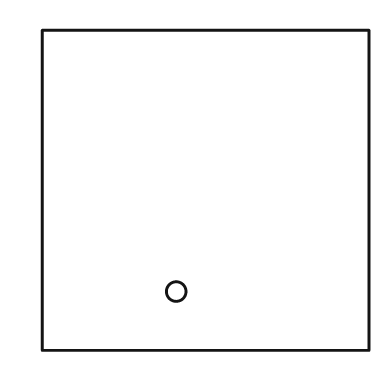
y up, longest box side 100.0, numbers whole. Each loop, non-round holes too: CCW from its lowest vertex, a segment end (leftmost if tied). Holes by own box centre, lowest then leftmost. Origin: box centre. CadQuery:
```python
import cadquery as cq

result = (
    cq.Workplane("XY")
    .moveTo(-50.0, -49.0)
    .lineTo(50.0, -49.0)
    .lineTo(50.0, 49.0)
    .lineTo(-50.0, 49.0)
    .close()
    .moveTo(-9.0, -31.0)
    .circle(3.0)
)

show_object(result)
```